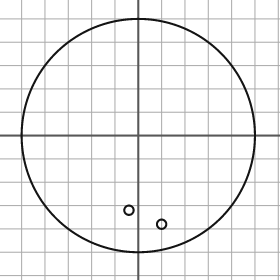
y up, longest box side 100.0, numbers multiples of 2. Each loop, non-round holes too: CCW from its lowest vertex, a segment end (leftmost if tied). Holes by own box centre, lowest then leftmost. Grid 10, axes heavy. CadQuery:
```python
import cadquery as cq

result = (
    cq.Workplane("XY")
    .moveTo(0.0, 0.0)
    .circle(50.0)
    .moveTo(10.0, -38.0)
    .circle(2.0)
    .moveTo(-4.0, -32.0)
    .circle(2.0)
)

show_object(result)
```